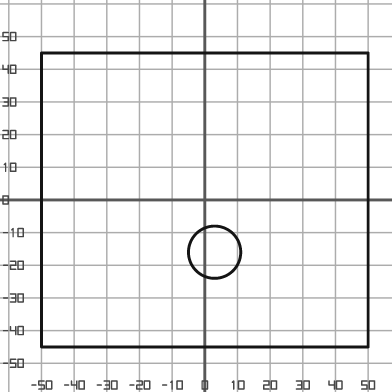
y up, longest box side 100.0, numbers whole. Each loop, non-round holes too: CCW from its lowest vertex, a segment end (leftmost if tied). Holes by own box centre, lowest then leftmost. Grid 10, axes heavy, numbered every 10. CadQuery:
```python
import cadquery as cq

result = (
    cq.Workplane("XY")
    .moveTo(-50.0, -45.0)
    .lineTo(50.0, -45.0)
    .lineTo(50.0, 45.0)
    .lineTo(-50.0, 45.0)
    .close()
    .moveTo(3.0, -16.0)
    .circle(8.0)
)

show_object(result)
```